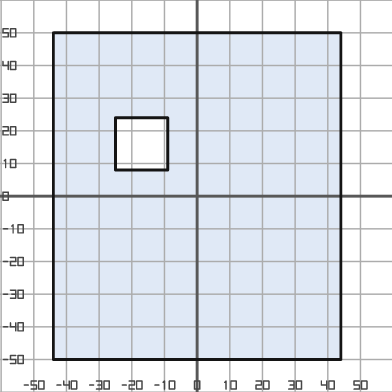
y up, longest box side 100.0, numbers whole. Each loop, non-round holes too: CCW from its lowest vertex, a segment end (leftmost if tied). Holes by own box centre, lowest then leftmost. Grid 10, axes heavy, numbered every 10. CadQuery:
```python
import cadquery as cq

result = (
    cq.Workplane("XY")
    .moveTo(-44.0, -50.0)
    .lineTo(44.0, -50.0)
    .lineTo(44.0, 50.0)
    .lineTo(-44.0, 50.0)
    .close()
    .moveTo(-25.0, 8.0)
    .lineTo(-9.0, 8.0)
    .lineTo(-9.0, 24.0)
    .lineTo(-25.0, 24.0)
    .close()
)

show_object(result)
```